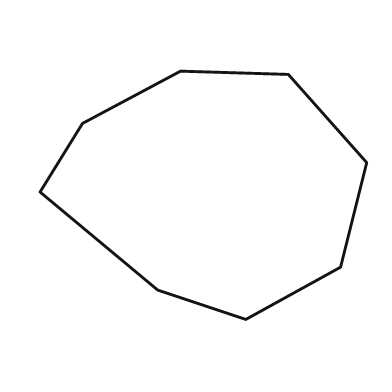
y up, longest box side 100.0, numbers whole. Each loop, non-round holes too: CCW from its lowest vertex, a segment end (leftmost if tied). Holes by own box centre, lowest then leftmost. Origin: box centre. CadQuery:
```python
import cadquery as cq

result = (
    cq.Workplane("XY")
    .moveTo(13.0, -38.0)
    .lineTo(42.0, -22.0)
    .lineTo(50.0, 10.0)
    .lineTo(26.0, 37.0)
    .lineTo(-7.0, 38.0)
    .lineTo(-37.0, 22.0)
    .lineTo(-50.0, 1.0)
    .lineTo(-14.0, -29.0)
    .close()
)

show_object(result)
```